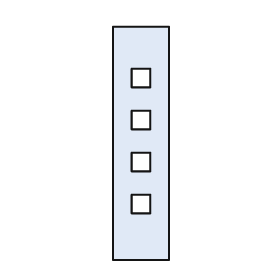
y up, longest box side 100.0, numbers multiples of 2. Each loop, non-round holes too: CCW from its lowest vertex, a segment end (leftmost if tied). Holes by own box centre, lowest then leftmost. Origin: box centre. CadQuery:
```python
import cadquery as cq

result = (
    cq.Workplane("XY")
    .moveTo(-12.0, -50.0)
    .lineTo(12.0, -50.0)
    .lineTo(12.0, 50.0)
    .lineTo(-12.0, 50.0)
    .close()
    .moveTo(-4.0, -30.0)
    .lineTo(4.0, -30.0)
    .lineTo(4.0, -22.0)
    .lineTo(-4.0, -22.0)
    .close()
    .moveTo(-4.0, -12.0)
    .lineTo(4.0, -12.0)
    .lineTo(4.0, -4.0)
    .lineTo(-4.0, -4.0)
    .close()
    .moveTo(-4.0, 6.0)
    .lineTo(4.0, 6.0)
    .lineTo(4.0, 14.0)
    .lineTo(-4.0, 14.0)
    .close()
    .moveTo(-4.0, 24.0)
    .lineTo(4.0, 24.0)
    .lineTo(4.0, 32.0)
    .lineTo(-4.0, 32.0)
    .close()
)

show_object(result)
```